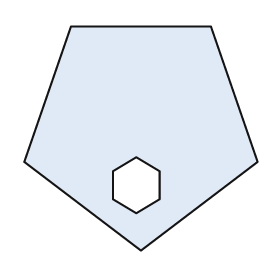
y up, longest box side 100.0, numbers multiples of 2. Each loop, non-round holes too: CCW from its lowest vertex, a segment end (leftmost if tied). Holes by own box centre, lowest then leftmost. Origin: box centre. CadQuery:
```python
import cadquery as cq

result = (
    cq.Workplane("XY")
    .moveTo(0.0, -48.0)
    .lineTo(50.0, -10.0)
    .lineTo(30.0, 48.0)
    .lineTo(-30.0, 48.0)
    .lineTo(-50.0, -10.0)
    .close()
    .moveTo(-2.0, -32.0)
    .lineTo(8.0, -26.0)
    .lineTo(8.0, -14.0)
    .lineTo(-2.0, -8.0)
    .lineTo(-12.0, -14.0)
    .lineTo(-12.0, -26.0)
    .close()
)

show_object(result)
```